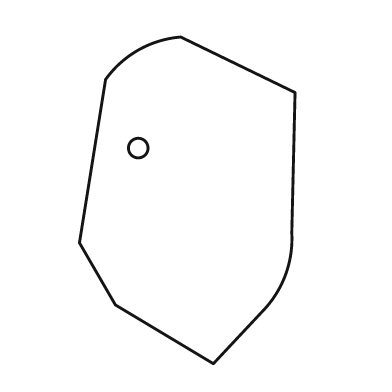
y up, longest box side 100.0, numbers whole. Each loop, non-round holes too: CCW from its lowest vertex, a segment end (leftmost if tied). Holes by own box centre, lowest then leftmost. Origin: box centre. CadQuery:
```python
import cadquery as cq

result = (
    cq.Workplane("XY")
    .moveTo(8.0, -50.0)
    .lineTo(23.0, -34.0)
    .threePointArc((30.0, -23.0), (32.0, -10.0))
    .lineTo(33.0, 33.0)
    .lineTo(-2.0, 50.0)
    .threePointArc((-15.0, 46.0), (-25.0, 37.0))
    .lineTo(-33.0, -13.0)
    .lineTo(-22.0, -32.0)
    .close()
    .moveTo(-15.0, 16.0)
    .circle(3.0)
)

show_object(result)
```